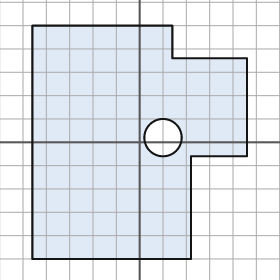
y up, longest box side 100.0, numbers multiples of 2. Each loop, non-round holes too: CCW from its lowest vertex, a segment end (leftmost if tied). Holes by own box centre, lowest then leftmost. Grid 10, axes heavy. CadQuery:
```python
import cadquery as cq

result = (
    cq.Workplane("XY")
    .moveTo(-46.0, -50.0)
    .lineTo(22.0, -50.0)
    .lineTo(22.0, -6.0)
    .lineTo(46.0, -6.0)
    .lineTo(46.0, 36.0)
    .lineTo(14.0, 36.0)
    .lineTo(14.0, 50.0)
    .lineTo(-46.0, 50.0)
    .close()
    .moveTo(10.0, 2.0)
    .circle(8.0)
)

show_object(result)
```